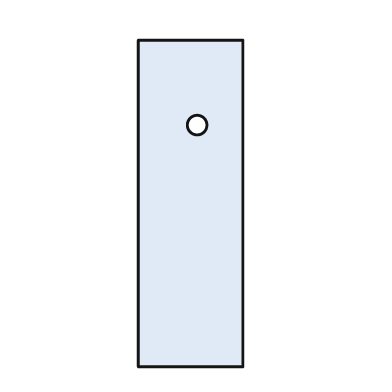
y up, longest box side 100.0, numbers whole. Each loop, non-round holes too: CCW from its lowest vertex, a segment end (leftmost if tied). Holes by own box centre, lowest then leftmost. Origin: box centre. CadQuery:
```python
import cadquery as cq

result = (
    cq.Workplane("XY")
    .moveTo(-16.0, -50.0)
    .lineTo(16.0, -50.0)
    .lineTo(16.0, 50.0)
    .lineTo(-16.0, 50.0)
    .close()
    .moveTo(2.0, 24.0)
    .circle(3.0)
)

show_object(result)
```